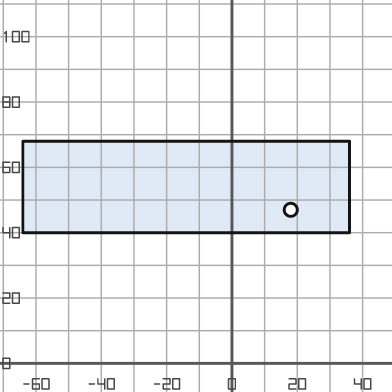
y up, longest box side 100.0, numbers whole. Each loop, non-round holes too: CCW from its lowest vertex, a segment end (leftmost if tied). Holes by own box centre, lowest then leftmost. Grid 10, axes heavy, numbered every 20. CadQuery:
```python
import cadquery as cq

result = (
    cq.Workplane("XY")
    .moveTo(-64.0, 40.0)
    .lineTo(36.0, 40.0)
    .lineTo(36.0, 68.0)
    .lineTo(-64.0, 68.0)
    .close()
    .moveTo(18.0, 47.0)
    .circle(2.0)
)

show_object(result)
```